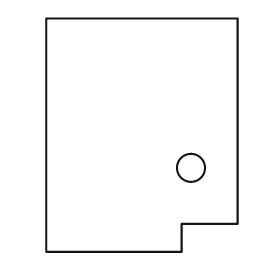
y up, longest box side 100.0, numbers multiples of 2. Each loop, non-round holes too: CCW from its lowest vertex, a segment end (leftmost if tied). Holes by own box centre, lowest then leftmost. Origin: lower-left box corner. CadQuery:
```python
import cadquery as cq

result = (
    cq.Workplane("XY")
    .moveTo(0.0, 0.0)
    .lineTo(58.0, 0.0)
    .lineTo(58.0, 12.0)
    .lineTo(82.0, 12.0)
    .lineTo(82.0, 100.0)
    .lineTo(0.0, 100.0)
    .close()
    .moveTo(62.0, 36.0)
    .circle(6.0)
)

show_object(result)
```